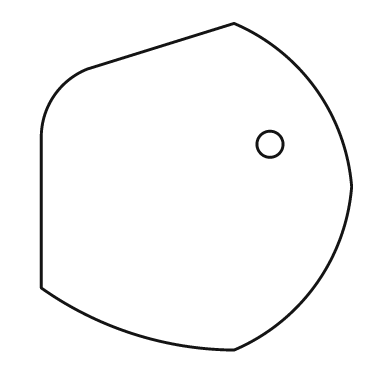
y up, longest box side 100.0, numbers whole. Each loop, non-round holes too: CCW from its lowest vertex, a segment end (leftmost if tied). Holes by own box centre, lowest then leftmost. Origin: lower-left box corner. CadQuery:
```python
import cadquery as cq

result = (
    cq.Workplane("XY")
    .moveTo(59.0, 0.0)
    .threePointArc((84.0, 20.0), (95.0, 50.0))
    .threePointArc((84.0, 80.0), (59.0, 100.0))
    .lineTo(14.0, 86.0)
    .threePointArc((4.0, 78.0), (0.0, 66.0))
    .lineTo(0.0, 19.0)
    .threePointArc((28.0, 5.0), (59.0, 0.0))
    .close()
    .moveTo(70.0, 63.0)
    .circle(4.0)
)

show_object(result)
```